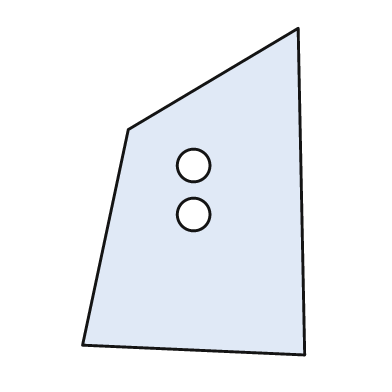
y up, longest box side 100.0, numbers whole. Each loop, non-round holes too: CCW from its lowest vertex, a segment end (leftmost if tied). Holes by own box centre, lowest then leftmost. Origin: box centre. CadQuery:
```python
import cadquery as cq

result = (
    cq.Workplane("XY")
    .moveTo(34.0, -50.0)
    .lineTo(32.0, 50.0)
    .lineTo(-20.0, 19.0)
    .lineTo(-34.0, -47.0)
    .close()
    .moveTo(0.0, -7.0)
    .circle(5.0)
    .moveTo(0.0, 8.0)
    .circle(5.0)
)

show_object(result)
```